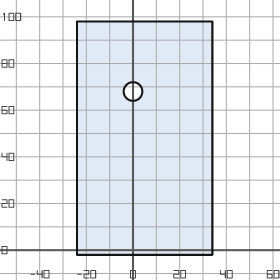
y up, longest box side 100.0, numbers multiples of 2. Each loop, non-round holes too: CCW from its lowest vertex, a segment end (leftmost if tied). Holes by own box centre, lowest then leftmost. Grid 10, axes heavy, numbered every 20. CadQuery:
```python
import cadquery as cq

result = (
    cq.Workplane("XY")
    .moveTo(-24.0, -2.0)
    .lineTo(34.0, -2.0)
    .lineTo(34.0, 98.0)
    .lineTo(-24.0, 98.0)
    .close()
    .moveTo(0.0, 68.0)
    .circle(4.0)
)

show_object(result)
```